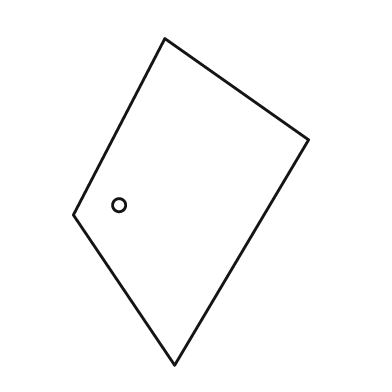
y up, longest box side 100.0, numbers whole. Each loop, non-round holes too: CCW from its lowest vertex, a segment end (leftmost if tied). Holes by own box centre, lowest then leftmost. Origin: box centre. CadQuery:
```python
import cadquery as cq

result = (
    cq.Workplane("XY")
    .moveTo(-5.0, -50.0)
    .lineTo(36.0, 19.0)
    .lineTo(-8.0, 50.0)
    .lineTo(-36.0, -4.0)
    .close()
    .moveTo(-22.0, -1.0)
    .circle(2.0)
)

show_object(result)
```